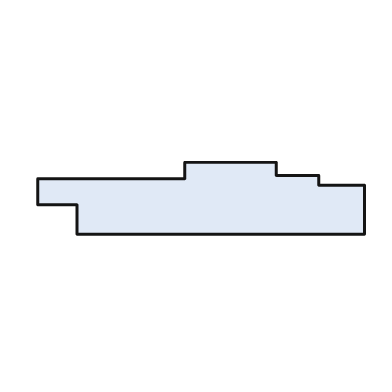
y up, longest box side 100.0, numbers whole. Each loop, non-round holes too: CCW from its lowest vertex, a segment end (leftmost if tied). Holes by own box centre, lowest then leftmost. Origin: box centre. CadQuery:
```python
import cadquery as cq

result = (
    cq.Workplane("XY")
    .moveTo(-38.0, -11.0)
    .lineTo(50.0, -11.0)
    .lineTo(50.0, 4.0)
    .lineTo(36.0, 4.0)
    .lineTo(36.0, 7.0)
    .lineTo(23.0, 7.0)
    .lineTo(23.0, 11.0)
    .lineTo(-5.0, 11.0)
    .lineTo(-5.0, 6.0)
    .lineTo(-50.0, 6.0)
    .lineTo(-50.0, -2.0)
    .lineTo(-38.0, -2.0)
    .close()
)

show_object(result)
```